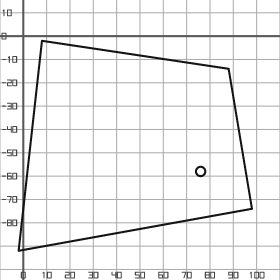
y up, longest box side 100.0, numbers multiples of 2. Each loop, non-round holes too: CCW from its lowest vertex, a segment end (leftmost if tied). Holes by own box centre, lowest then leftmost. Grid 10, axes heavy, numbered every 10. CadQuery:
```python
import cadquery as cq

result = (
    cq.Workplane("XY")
    .moveTo(-2.0, -92.0)
    .lineTo(98.0, -74.0)
    .lineTo(88.0, -14.0)
    .lineTo(8.0, -2.0)
    .close()
    .moveTo(76.0, -58.0)
    .circle(2.0)
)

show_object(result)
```